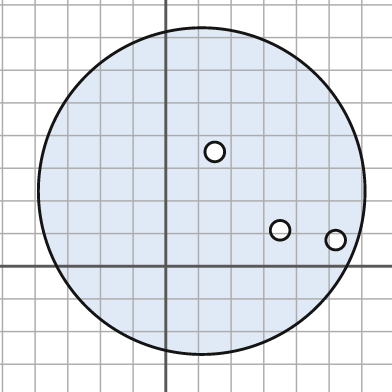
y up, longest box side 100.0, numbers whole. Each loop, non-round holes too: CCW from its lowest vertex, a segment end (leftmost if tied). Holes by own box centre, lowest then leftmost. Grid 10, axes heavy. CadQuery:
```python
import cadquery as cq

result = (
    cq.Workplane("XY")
    .moveTo(11.0, 23.0)
    .circle(50.0)
    .moveTo(52.0, 8.0)
    .circle(3.0)
    .moveTo(35.0, 11.0)
    .circle(3.0)
    .moveTo(15.0, 35.0)
    .circle(3.0)
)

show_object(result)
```